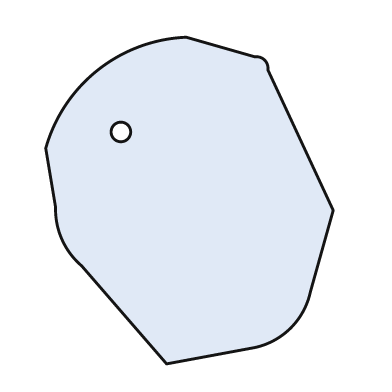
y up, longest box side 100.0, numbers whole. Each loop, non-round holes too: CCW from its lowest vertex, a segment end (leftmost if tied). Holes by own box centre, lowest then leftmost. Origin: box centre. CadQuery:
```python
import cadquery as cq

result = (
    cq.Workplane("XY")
    .moveTo(-7.0, -50.0)
    .lineTo(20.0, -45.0)
    .threePointArc((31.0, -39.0), (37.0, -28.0))
    .lineTo(44.0, -3.0)
    .lineTo(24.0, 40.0)
    .threePointArc((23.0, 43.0), (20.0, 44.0))
    .lineTo(-1.0, 50.0)
    .threePointArc((-28.0, 40.0), (-44.0, 16.0))
    .lineTo(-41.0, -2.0)
    .threePointArc((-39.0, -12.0), (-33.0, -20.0))
    .close()
    .moveTo(-21.0, 21.0)
    .circle(3.0)
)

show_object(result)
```